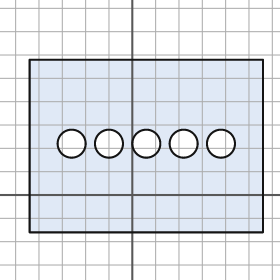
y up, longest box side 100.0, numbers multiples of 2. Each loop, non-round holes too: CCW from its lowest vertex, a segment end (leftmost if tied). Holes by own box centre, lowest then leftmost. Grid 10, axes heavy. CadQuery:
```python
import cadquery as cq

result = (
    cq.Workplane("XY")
    .moveTo(-44.0, -16.0)
    .lineTo(56.0, -16.0)
    .lineTo(56.0, 58.0)
    .lineTo(-44.0, 58.0)
    .close()
    .moveTo(-26.0, 22.0)
    .circle(6.0)
    .moveTo(-10.0, 22.0)
    .circle(6.0)
    .moveTo(6.0, 22.0)
    .circle(6.0)
    .moveTo(22.0, 22.0)
    .circle(6.0)
    .moveTo(38.0, 22.0)
    .circle(6.0)
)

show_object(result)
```